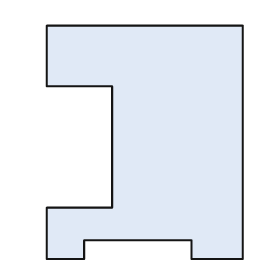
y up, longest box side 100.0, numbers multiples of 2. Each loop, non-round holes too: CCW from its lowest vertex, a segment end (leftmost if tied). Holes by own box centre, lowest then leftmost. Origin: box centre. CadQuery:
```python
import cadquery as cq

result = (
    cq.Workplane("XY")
    .moveTo(-42.0, -50.0)
    .lineTo(-26.0, -50.0)
    .lineTo(-26.0, -42.0)
    .lineTo(20.0, -42.0)
    .lineTo(20.0, -50.0)
    .lineTo(42.0, -50.0)
    .lineTo(42.0, 50.0)
    .lineTo(-42.0, 50.0)
    .lineTo(-42.0, 24.0)
    .lineTo(-14.0, 24.0)
    .lineTo(-14.0, -28.0)
    .lineTo(-42.0, -28.0)
    .close()
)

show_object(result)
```